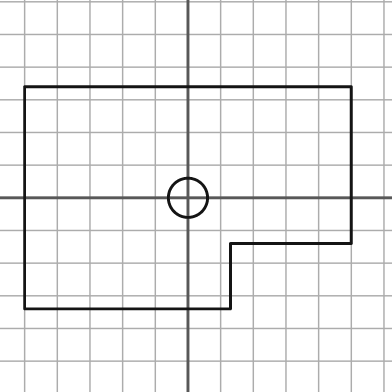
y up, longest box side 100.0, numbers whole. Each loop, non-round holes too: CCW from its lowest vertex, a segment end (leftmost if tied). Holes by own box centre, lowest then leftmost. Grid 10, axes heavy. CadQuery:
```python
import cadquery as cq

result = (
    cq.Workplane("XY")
    .moveTo(-50.0, -34.0)
    .lineTo(13.0, -34.0)
    .lineTo(13.0, -14.0)
    .lineTo(50.0, -14.0)
    .lineTo(50.0, 34.0)
    .lineTo(-50.0, 34.0)
    .close()
    .moveTo(0.0, 0.0)
    .circle(6.0)
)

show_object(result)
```